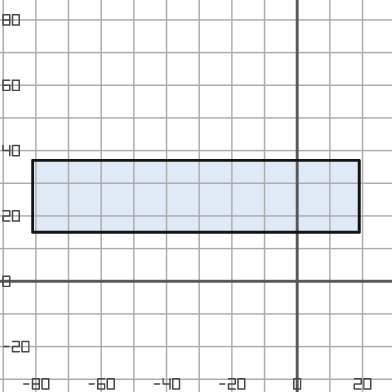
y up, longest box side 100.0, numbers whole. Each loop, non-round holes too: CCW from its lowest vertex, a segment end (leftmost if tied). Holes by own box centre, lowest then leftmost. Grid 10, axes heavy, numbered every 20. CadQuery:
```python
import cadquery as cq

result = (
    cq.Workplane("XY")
    .moveTo(-81.0, 15.0)
    .lineTo(19.0, 15.0)
    .lineTo(19.0, 37.0)
    .lineTo(-81.0, 37.0)
    .close()
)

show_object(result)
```